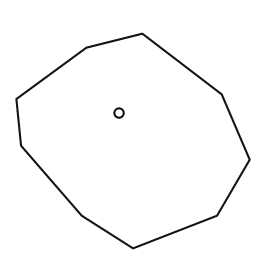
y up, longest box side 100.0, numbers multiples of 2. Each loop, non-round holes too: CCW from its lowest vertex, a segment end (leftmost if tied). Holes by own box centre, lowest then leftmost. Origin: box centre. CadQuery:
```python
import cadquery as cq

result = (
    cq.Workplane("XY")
    .moveTo(0.0, -46.0)
    .lineTo(36.0, -32.0)
    .lineTo(50.0, -8.0)
    .lineTo(38.0, 20.0)
    .lineTo(4.0, 46.0)
    .lineTo(-20.0, 40.0)
    .lineTo(-50.0, 18.0)
    .lineTo(-48.0, -2.0)
    .lineTo(-22.0, -32.0)
    .close()
    .moveTo(-6.0, 12.0)
    .circle(2.0)
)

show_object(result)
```